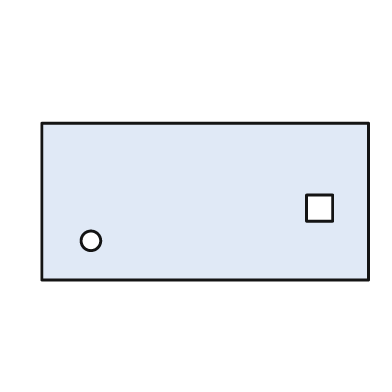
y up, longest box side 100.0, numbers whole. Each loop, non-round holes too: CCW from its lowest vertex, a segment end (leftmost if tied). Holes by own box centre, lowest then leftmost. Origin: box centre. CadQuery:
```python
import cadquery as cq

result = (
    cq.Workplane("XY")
    .moveTo(-50.0, -24.0)
    .lineTo(50.0, -24.0)
    .lineTo(50.0, 24.0)
    .lineTo(-50.0, 24.0)
    .close()
    .moveTo(-35.0, -12.0)
    .circle(3.0)
    .moveTo(31.0, -6.0)
    .lineTo(39.0, -6.0)
    .lineTo(39.0, 2.0)
    .lineTo(31.0, 2.0)
    .close()
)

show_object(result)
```